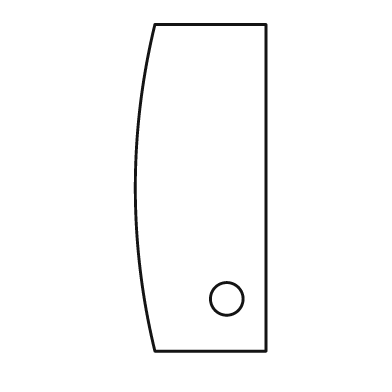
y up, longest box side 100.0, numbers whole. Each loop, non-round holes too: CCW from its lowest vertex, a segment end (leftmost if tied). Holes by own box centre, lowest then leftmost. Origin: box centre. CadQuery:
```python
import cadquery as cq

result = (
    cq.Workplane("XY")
    .moveTo(-14.0, -50.0)
    .lineTo(20.0, -50.0)
    .lineTo(20.0, 50.0)
    .lineTo(-14.0, 50.0)
    .threePointArc((-20.0, 0.0), (-14.0, -50.0))
    .close()
    .moveTo(8.0, -34.0)
    .circle(5.0)
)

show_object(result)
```